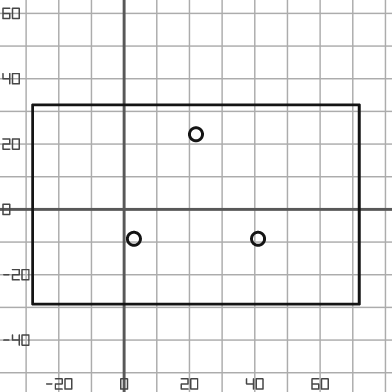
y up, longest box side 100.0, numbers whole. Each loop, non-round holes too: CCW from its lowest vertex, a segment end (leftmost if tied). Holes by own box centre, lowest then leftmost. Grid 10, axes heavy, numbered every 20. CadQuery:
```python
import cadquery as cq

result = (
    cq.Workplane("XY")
    .moveTo(-28.0, -29.0)
    .lineTo(72.0, -29.0)
    .lineTo(72.0, 32.0)
    .lineTo(-28.0, 32.0)
    .close()
    .moveTo(3.0, -9.0)
    .circle(2.0)
    .moveTo(41.0, -9.0)
    .circle(2.0)
    .moveTo(22.0, 23.0)
    .circle(2.0)
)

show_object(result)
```